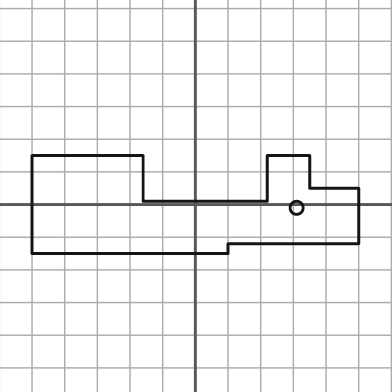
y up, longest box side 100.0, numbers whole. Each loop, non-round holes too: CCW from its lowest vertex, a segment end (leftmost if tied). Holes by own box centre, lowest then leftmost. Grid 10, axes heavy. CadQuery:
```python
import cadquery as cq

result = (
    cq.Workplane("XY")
    .moveTo(-50.0, -15.0)
    .lineTo(10.0, -15.0)
    .lineTo(10.0, -12.0)
    .lineTo(50.0, -12.0)
    .lineTo(50.0, 5.0)
    .lineTo(35.0, 5.0)
    .lineTo(35.0, 15.0)
    .lineTo(22.0, 15.0)
    .lineTo(22.0, 1.0)
    .lineTo(-16.0, 1.0)
    .lineTo(-16.0, 15.0)
    .lineTo(-50.0, 15.0)
    .close()
    .moveTo(31.0, -1.0)
    .circle(2.0)
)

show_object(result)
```